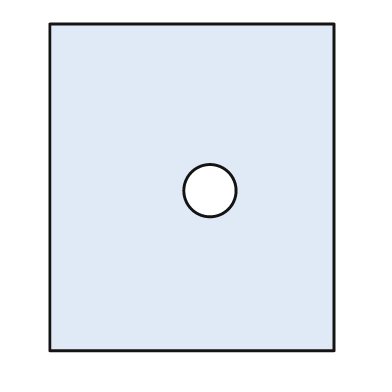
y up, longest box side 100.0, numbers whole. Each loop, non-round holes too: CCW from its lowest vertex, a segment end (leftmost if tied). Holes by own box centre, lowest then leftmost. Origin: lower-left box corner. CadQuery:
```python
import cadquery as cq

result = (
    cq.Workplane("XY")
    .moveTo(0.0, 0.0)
    .lineTo(87.0, 0.0)
    .lineTo(87.0, 100.0)
    .lineTo(0.0, 100.0)
    .close()
    .moveTo(49.0, 49.0)
    .circle(8.0)
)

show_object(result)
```